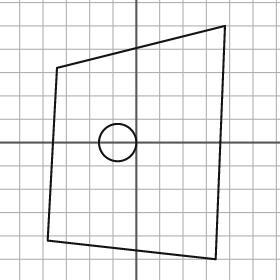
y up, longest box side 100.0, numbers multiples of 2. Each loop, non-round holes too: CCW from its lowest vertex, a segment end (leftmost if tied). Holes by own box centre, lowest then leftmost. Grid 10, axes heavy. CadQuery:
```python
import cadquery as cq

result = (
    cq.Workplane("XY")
    .moveTo(34.0, -50.0)
    .lineTo(38.0, 50.0)
    .lineTo(-34.0, 32.0)
    .lineTo(-38.0, -42.0)
    .close()
    .moveTo(-8.0, 0.0)
    .circle(8.0)
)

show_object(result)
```